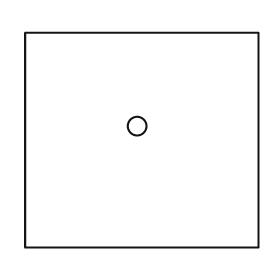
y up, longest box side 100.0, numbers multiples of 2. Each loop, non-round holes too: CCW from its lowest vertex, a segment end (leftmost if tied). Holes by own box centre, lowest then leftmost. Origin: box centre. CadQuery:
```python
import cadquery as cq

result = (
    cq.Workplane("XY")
    .moveTo(-50.0, -46.0)
    .lineTo(50.0, -46.0)
    .lineTo(50.0, 46.0)
    .lineTo(-50.0, 46.0)
    .close()
    .moveTo(-2.0, 6.0)
    .circle(4.0)
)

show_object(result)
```